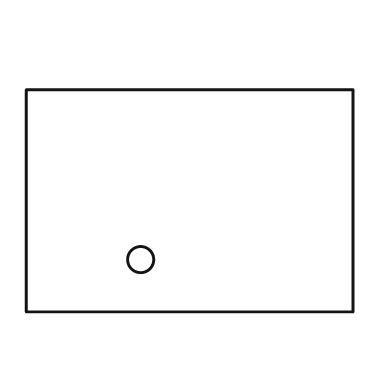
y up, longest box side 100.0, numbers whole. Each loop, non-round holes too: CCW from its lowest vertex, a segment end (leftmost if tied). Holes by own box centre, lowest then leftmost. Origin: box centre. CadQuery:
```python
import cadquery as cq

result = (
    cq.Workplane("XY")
    .moveTo(-50.0, -34.0)
    .lineTo(50.0, -34.0)
    .lineTo(50.0, 34.0)
    .lineTo(-50.0, 34.0)
    .close()
    .moveTo(-15.0, -18.0)
    .circle(4.0)
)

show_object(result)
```